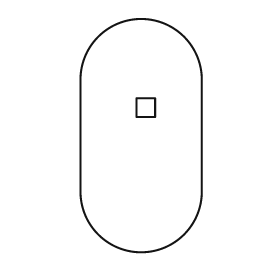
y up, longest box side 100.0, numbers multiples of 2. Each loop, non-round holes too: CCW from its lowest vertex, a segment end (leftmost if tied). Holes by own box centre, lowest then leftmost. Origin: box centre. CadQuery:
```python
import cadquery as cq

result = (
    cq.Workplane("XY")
    .moveTo(-26.0, -24.0)
    .threePointArc((0.0, -50.0), (26.0, -24.0))
    .lineTo(26.0, 24.0)
    .threePointArc((0.0, 50.0), (-26.0, 24.0))
    .close()
    .moveTo(-2.0, 8.0)
    .lineTo(6.0, 8.0)
    .lineTo(6.0, 16.0)
    .lineTo(-2.0, 16.0)
    .close()
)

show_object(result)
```